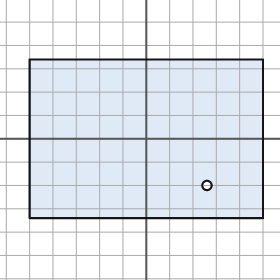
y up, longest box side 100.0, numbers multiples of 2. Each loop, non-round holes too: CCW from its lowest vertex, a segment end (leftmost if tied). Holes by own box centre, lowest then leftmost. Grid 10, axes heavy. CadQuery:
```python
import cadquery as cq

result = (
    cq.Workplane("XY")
    .moveTo(-50.0, -34.0)
    .lineTo(50.0, -34.0)
    .lineTo(50.0, 34.0)
    .lineTo(-50.0, 34.0)
    .close()
    .moveTo(26.0, -20.0)
    .circle(2.0)
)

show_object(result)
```